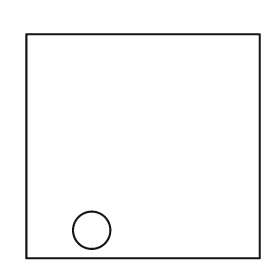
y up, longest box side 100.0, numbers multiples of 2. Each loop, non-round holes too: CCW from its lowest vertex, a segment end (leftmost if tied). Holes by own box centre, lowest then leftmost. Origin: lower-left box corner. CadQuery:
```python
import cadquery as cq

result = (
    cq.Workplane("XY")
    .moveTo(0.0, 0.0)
    .lineTo(100.0, 0.0)
    .lineTo(100.0, 96.0)
    .lineTo(0.0, 96.0)
    .close()
    .moveTo(28.0, 12.0)
    .circle(8.0)
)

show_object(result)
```